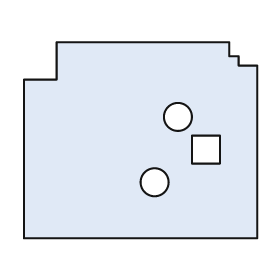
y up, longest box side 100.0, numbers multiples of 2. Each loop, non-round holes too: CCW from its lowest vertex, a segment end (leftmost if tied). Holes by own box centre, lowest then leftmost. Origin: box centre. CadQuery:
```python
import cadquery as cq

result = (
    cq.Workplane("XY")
    .moveTo(-50.0, -42.0)
    .lineTo(50.0, -42.0)
    .lineTo(50.0, 32.0)
    .lineTo(42.0, 32.0)
    .lineTo(42.0, 36.0)
    .lineTo(38.0, 36.0)
    .lineTo(38.0, 42.0)
    .lineTo(-36.0, 42.0)
    .lineTo(-36.0, 26.0)
    .lineTo(-50.0, 26.0)
    .close()
    .moveTo(6.0, -18.0)
    .circle(6.0)
    .moveTo(22.0, -10.0)
    .lineTo(34.0, -10.0)
    .lineTo(34.0, 2.0)
    .lineTo(22.0, 2.0)
    .close()
    .moveTo(16.0, 10.0)
    .circle(6.0)
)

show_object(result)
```